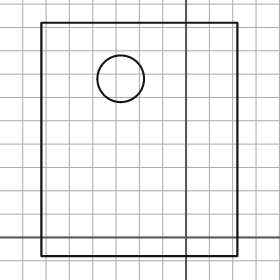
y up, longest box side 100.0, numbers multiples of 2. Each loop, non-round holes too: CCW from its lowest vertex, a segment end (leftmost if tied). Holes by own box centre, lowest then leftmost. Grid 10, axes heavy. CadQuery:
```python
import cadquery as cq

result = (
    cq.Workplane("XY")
    .moveTo(-62.0, -8.0)
    .lineTo(22.0, -8.0)
    .lineTo(22.0, 92.0)
    .lineTo(-62.0, 92.0)
    .close()
    .moveTo(-28.0, 68.0)
    .circle(10.0)
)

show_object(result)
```